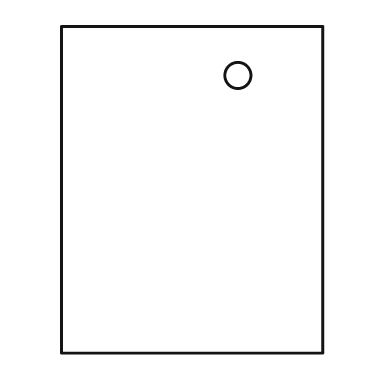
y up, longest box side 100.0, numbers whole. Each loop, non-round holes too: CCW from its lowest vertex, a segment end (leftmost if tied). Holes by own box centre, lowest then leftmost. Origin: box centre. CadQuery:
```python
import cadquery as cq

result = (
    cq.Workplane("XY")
    .moveTo(-40.0, -50.0)
    .lineTo(40.0, -50.0)
    .lineTo(40.0, 50.0)
    .lineTo(-40.0, 50.0)
    .close()
    .moveTo(14.0, 35.0)
    .circle(4.0)
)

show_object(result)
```